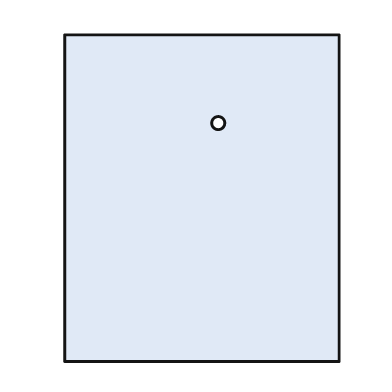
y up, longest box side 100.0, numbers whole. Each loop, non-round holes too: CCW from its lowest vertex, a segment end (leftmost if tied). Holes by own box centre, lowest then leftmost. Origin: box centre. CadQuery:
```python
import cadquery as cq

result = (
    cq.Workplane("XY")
    .moveTo(-42.0, -50.0)
    .lineTo(42.0, -50.0)
    .lineTo(42.0, 50.0)
    .lineTo(-42.0, 50.0)
    .close()
    .moveTo(5.0, 23.0)
    .circle(2.0)
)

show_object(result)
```